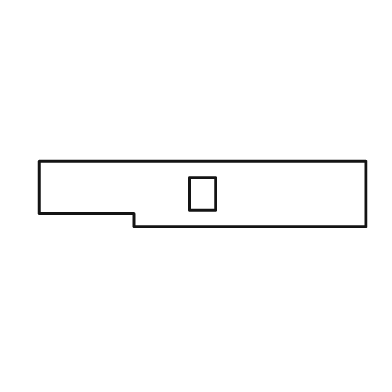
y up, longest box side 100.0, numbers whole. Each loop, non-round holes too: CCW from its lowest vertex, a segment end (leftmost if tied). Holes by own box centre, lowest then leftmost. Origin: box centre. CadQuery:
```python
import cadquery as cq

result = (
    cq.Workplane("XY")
    .moveTo(-21.0, -10.0)
    .lineTo(50.0, -10.0)
    .lineTo(50.0, 10.0)
    .lineTo(-50.0, 10.0)
    .lineTo(-50.0, -6.0)
    .lineTo(-21.0, -6.0)
    .close()
    .moveTo(-4.0, -5.0)
    .lineTo(4.0, -5.0)
    .lineTo(4.0, 5.0)
    .lineTo(-4.0, 5.0)
    .close()
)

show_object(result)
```